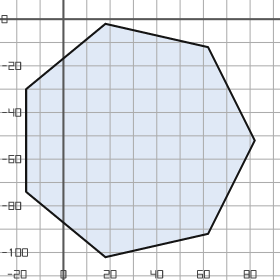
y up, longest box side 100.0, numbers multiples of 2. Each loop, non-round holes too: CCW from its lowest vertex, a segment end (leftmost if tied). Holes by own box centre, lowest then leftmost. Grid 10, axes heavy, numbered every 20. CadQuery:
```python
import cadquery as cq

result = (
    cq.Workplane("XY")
    .moveTo(18.0, -102.0)
    .lineTo(62.0, -92.0)
    .lineTo(82.0, -52.0)
    .lineTo(62.0, -12.0)
    .lineTo(18.0, -2.0)
    .lineTo(-16.0, -30.0)
    .lineTo(-16.0, -74.0)
    .close()
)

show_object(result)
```